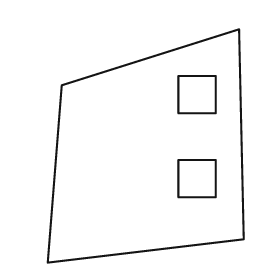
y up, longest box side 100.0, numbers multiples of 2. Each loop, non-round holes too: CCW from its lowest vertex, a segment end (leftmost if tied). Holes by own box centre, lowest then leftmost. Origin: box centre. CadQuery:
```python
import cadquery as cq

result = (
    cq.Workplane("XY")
    .moveTo(-42.0, -50.0)
    .lineTo(42.0, -40.0)
    .lineTo(40.0, 50.0)
    .lineTo(-36.0, 26.0)
    .close()
    .moveTo(14.0, -22.0)
    .lineTo(30.0, -22.0)
    .lineTo(30.0, -6.0)
    .lineTo(14.0, -6.0)
    .close()
    .moveTo(14.0, 14.0)
    .lineTo(30.0, 14.0)
    .lineTo(30.0, 30.0)
    .lineTo(14.0, 30.0)
    .close()
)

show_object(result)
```